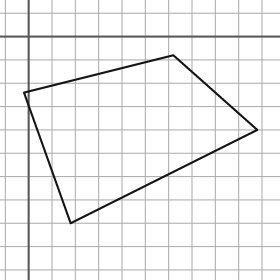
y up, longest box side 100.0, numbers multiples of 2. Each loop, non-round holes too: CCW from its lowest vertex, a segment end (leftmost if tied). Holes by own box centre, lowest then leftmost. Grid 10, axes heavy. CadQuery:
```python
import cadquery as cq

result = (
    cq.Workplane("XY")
    .moveTo(18.0, -80.0)
    .lineTo(98.0, -40.0)
    .lineTo(62.0, -8.0)
    .lineTo(-2.0, -24.0)
    .close()
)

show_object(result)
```